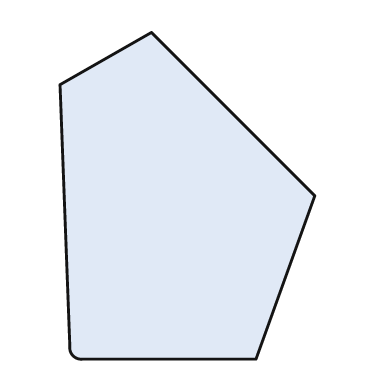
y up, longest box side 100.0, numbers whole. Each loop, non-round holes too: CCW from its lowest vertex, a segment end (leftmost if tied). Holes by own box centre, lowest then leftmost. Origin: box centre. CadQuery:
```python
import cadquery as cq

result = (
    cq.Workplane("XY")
    .moveTo(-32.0, -50.0)
    .lineTo(21.0, -50.0)
    .lineTo(39.0, 0.0)
    .lineTo(-11.0, 50.0)
    .lineTo(-39.0, 34.0)
    .lineTo(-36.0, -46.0)
    .threePointArc((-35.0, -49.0), (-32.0, -50.0))
    .close()
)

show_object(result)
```